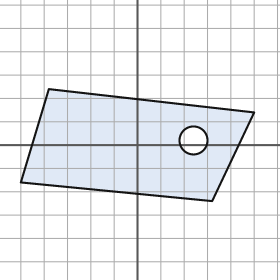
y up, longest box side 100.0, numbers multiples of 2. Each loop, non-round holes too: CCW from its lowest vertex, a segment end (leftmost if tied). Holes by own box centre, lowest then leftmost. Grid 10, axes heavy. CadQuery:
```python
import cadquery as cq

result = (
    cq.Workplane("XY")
    .moveTo(32.0, -24.0)
    .lineTo(50.0, 14.0)
    .lineTo(-38.0, 24.0)
    .lineTo(-50.0, -16.0)
    .close()
    .moveTo(24.0, 2.0)
    .circle(6.0)
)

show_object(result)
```